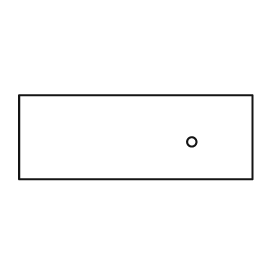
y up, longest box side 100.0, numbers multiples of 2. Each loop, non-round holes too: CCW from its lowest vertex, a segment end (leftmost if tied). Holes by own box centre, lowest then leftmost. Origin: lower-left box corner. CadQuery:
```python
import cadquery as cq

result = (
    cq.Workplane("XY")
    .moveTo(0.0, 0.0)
    .lineTo(100.0, 0.0)
    .lineTo(100.0, 36.0)
    .lineTo(0.0, 36.0)
    .close()
    .moveTo(74.0, 16.0)
    .circle(2.0)
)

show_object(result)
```